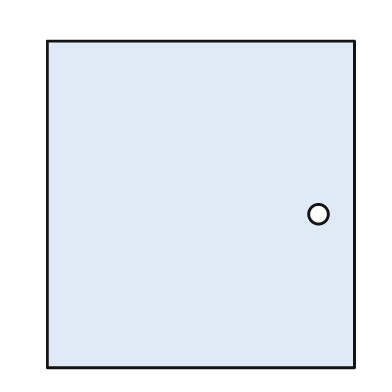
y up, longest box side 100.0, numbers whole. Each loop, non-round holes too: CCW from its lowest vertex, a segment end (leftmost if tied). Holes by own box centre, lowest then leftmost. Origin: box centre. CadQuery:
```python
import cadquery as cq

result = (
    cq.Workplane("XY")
    .moveTo(-47.0, -50.0)
    .lineTo(47.0, -50.0)
    .lineTo(47.0, 50.0)
    .lineTo(-47.0, 50.0)
    .close()
    .moveTo(36.0, -3.0)
    .circle(3.0)
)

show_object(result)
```